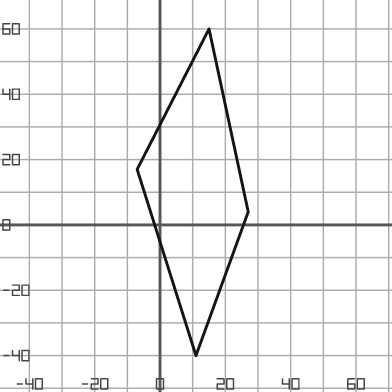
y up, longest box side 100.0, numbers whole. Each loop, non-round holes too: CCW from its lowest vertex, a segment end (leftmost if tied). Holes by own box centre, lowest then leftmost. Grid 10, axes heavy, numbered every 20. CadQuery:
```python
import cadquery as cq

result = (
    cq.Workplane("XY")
    .moveTo(11.0, -40.0)
    .lineTo(27.0, 4.0)
    .lineTo(15.0, 60.0)
    .lineTo(-7.0, 17.0)
    .close()
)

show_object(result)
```